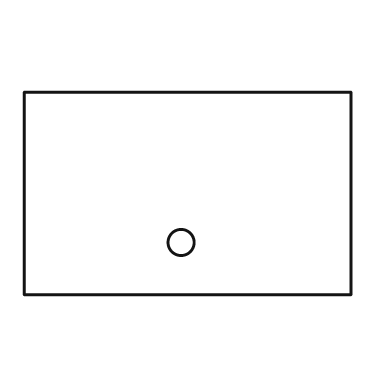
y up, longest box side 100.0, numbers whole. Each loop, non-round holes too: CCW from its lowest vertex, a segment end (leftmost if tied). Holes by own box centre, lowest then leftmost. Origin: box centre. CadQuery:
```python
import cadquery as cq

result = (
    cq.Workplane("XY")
    .moveTo(-50.0, -31.0)
    .lineTo(50.0, -31.0)
    .lineTo(50.0, 31.0)
    .lineTo(-50.0, 31.0)
    .close()
    .moveTo(-2.0, -15.0)
    .circle(4.0)
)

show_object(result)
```